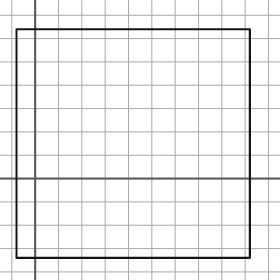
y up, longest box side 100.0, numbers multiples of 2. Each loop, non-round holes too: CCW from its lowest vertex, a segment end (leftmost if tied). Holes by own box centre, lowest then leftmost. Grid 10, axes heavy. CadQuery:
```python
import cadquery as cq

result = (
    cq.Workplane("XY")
    .moveTo(-8.0, -34.0)
    .lineTo(92.0, -34.0)
    .lineTo(92.0, 64.0)
    .lineTo(-8.0, 64.0)
    .close()
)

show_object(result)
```